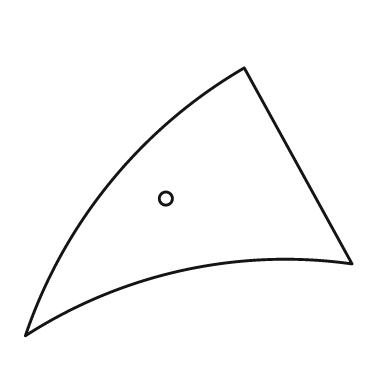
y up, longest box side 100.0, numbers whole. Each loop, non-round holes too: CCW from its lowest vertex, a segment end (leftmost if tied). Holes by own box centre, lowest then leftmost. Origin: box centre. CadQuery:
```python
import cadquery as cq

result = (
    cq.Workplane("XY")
    .moveTo(-50.0, -41.0)
    .threePointArc((-2.0, -21.0), (50.0, -19.0))
    .lineTo(17.0, 41.0)
    .threePointArc((-24.0, 6.0), (-50.0, -41.0))
    .close()
    .moveTo(-7.0, 1.0)
    .circle(2.0)
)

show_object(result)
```